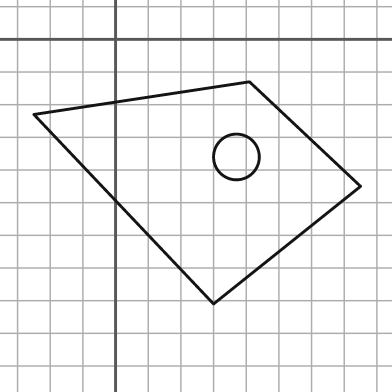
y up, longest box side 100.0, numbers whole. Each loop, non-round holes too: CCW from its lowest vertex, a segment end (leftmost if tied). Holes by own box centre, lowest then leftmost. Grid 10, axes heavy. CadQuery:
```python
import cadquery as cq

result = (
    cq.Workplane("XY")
    .moveTo(30.0, -81.0)
    .lineTo(75.0, -45.0)
    .lineTo(41.0, -13.0)
    .lineTo(-25.0, -23.0)
    .close()
    .moveTo(37.0, -36.0)
    .circle(7.0)
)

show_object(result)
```